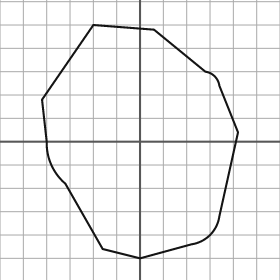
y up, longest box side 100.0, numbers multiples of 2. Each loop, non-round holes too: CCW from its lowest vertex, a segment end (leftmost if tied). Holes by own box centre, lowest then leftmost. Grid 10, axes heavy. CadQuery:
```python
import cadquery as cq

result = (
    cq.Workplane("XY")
    .moveTo(0.0, -50.0)
    .lineTo(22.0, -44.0)
    .threePointArc((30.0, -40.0), (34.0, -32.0))
    .lineTo(42.0, 4.0)
    .lineTo(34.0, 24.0)
    .threePointArc((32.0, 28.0), (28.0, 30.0))
    .lineTo(6.0, 48.0)
    .lineTo(-20.0, 50.0)
    .lineTo(-42.0, 18.0)
    .lineTo(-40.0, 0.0)
    .threePointArc((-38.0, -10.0), (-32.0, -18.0))
    .lineTo(-16.0, -46.0)
    .close()
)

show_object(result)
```